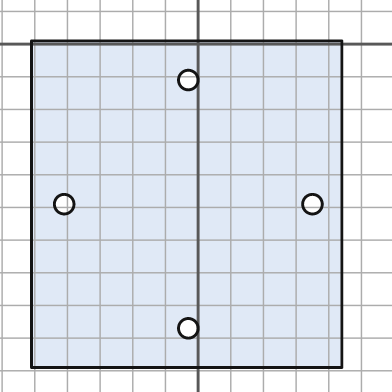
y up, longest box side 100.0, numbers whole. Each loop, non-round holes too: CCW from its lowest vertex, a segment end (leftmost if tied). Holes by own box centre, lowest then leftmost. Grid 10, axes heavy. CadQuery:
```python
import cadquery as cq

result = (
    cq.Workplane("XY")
    .moveTo(-51.0, -99.0)
    .lineTo(44.0, -99.0)
    .lineTo(44.0, 1.0)
    .lineTo(-51.0, 1.0)
    .close()
    .moveTo(-3.0, -87.0)
    .circle(3.0)
    .moveTo(-41.0, -49.0)
    .circle(3.0)
    .moveTo(35.0, -49.0)
    .circle(3.0)
    .moveTo(-3.0, -11.0)
    .circle(3.0)
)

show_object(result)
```